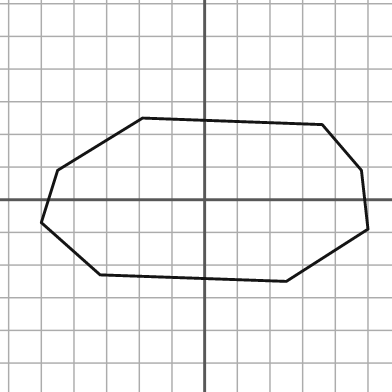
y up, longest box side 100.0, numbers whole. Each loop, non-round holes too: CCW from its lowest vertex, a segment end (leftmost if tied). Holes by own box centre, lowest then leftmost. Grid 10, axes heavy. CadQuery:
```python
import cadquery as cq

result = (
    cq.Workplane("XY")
    .moveTo(25.0, -25.0)
    .lineTo(50.0, -9.0)
    .lineTo(48.0, 9.0)
    .lineTo(36.0, 23.0)
    .lineTo(-19.0, 25.0)
    .lineTo(-45.0, 9.0)
    .lineTo(-50.0, -7.0)
    .lineTo(-32.0, -23.0)
    .close()
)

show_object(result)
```